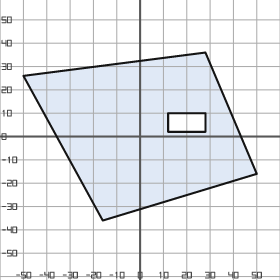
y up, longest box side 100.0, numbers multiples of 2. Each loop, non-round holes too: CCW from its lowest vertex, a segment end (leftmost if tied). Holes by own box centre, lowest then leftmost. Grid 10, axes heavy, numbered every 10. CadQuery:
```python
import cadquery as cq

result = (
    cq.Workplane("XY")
    .moveTo(-16.0, -36.0)
    .lineTo(50.0, -16.0)
    .lineTo(28.0, 36.0)
    .lineTo(-50.0, 26.0)
    .close()
    .moveTo(12.0, 2.0)
    .lineTo(28.0, 2.0)
    .lineTo(28.0, 10.0)
    .lineTo(12.0, 10.0)
    .close()
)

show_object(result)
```